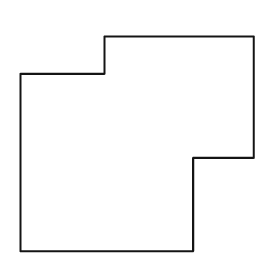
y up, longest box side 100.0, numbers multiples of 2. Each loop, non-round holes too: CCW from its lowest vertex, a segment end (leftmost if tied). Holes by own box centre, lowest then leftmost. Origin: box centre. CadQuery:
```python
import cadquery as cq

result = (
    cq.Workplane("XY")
    .moveTo(-50.0, -46.0)
    .lineTo(24.0, -46.0)
    .lineTo(24.0, -6.0)
    .lineTo(50.0, -6.0)
    .lineTo(50.0, 46.0)
    .lineTo(-14.0, 46.0)
    .lineTo(-14.0, 30.0)
    .lineTo(-50.0, 30.0)
    .close()
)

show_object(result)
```